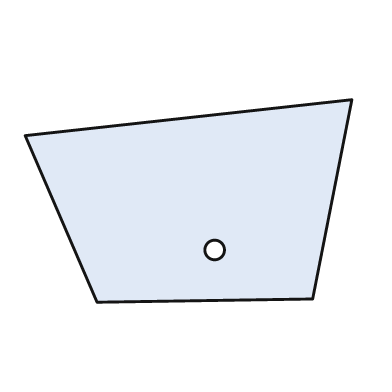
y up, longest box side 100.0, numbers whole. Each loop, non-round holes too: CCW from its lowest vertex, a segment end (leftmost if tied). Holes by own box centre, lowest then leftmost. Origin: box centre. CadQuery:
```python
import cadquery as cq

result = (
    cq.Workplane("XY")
    .moveTo(-28.0, -31.0)
    .lineTo(38.0, -30.0)
    .lineTo(50.0, 31.0)
    .lineTo(-50.0, 20.0)
    .close()
    .moveTo(8.0, -15.0)
    .circle(3.0)
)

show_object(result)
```